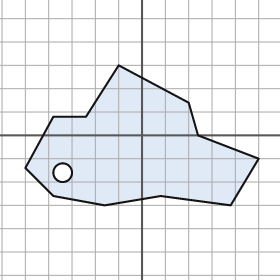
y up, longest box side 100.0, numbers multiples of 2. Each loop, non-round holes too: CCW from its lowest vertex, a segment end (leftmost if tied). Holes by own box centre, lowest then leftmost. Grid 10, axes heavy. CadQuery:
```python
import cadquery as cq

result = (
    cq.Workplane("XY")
    .moveTo(-16.0, -30.0)
    .lineTo(8.0, -26.0)
    .lineTo(38.0, -30.0)
    .lineTo(50.0, -10.0)
    .lineTo(24.0, 0.0)
    .lineTo(20.0, 14.0)
    .lineTo(-10.0, 30.0)
    .lineTo(-24.0, 8.0)
    .lineTo(-38.0, 8.0)
    .lineTo(-50.0, -14.0)
    .lineTo(-38.0, -26.0)
    .close()
    .moveTo(-34.0, -16.0)
    .circle(4.0)
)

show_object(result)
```